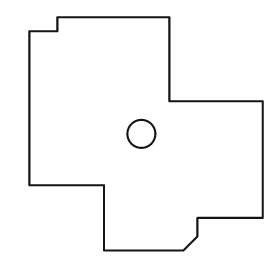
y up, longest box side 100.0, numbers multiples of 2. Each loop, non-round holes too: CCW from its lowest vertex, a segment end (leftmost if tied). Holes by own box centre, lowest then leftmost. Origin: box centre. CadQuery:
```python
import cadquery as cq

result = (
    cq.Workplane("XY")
    .moveTo(-18.0, -50.0)
    .lineTo(16.0, -50.0)
    .lineTo(22.0, -44.0)
    .lineTo(22.0, -36.0)
    .lineTo(50.0, -36.0)
    .lineTo(50.0, 14.0)
    .lineTo(10.0, 14.0)
    .lineTo(10.0, 50.0)
    .lineTo(-38.0, 50.0)
    .lineTo(-38.0, 44.0)
    .lineTo(-50.0, 44.0)
    .lineTo(-50.0, -22.0)
    .lineTo(-18.0, -22.0)
    .close()
    .moveTo(-2.0, 0.0)
    .circle(6.0)
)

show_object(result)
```